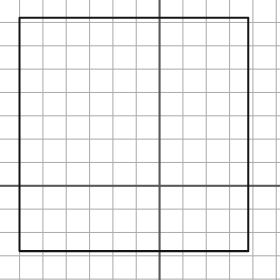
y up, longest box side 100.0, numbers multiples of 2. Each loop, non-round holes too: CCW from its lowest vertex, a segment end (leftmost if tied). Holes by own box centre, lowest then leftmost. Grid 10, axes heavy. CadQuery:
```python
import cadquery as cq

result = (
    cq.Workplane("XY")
    .moveTo(-60.0, -28.0)
    .lineTo(38.0, -28.0)
    .lineTo(38.0, 72.0)
    .lineTo(-60.0, 72.0)
    .close()
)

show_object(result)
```